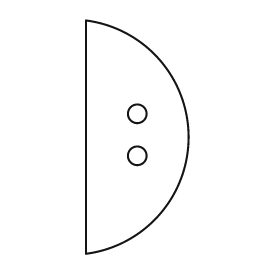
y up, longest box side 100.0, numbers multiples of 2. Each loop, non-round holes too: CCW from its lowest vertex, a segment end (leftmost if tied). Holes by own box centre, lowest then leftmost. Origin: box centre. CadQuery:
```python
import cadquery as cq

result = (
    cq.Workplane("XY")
    .moveTo(-22.0, -50.0)
    .threePointArc((22.0, 0.0), (-22.0, 50.0))
    .close()
    .moveTo(0.0, -8.0)
    .circle(4.0)
    .moveTo(0.0, 10.0)
    .circle(4.0)
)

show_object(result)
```